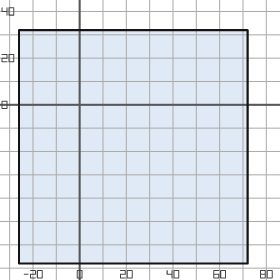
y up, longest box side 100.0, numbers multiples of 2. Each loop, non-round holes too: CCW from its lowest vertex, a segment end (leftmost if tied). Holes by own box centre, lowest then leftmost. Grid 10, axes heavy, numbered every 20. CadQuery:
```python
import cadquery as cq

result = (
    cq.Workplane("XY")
    .moveTo(-26.0, -68.0)
    .lineTo(72.0, -68.0)
    .lineTo(72.0, 32.0)
    .lineTo(-26.0, 32.0)
    .close()
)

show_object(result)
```